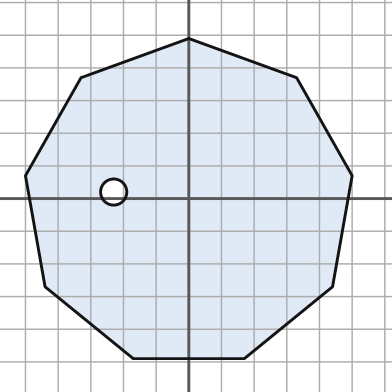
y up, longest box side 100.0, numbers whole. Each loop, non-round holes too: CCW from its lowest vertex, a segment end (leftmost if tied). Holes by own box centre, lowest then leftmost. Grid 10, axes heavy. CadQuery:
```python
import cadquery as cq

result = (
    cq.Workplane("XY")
    .moveTo(-17.0, -49.0)
    .lineTo(17.0, -49.0)
    .lineTo(44.0, -27.0)
    .lineTo(50.0, 7.0)
    .lineTo(33.0, 37.0)
    .lineTo(0.0, 49.0)
    .lineTo(-33.0, 37.0)
    .lineTo(-50.0, 7.0)
    .lineTo(-44.0, -27.0)
    .close()
    .moveTo(-23.0, 2.0)
    .circle(4.0)
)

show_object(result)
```